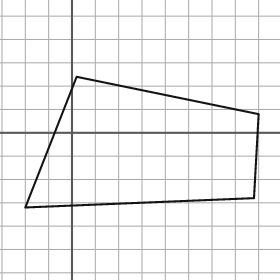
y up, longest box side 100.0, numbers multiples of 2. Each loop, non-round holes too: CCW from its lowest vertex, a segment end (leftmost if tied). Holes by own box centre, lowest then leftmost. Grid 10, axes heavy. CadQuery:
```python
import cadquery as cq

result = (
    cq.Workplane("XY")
    .moveTo(-20.0, -32.0)
    .lineTo(78.0, -28.0)
    .lineTo(80.0, 8.0)
    .lineTo(2.0, 24.0)
    .close()
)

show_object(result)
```